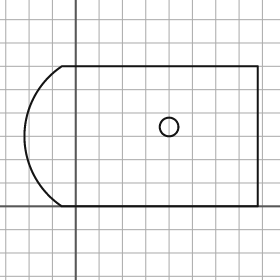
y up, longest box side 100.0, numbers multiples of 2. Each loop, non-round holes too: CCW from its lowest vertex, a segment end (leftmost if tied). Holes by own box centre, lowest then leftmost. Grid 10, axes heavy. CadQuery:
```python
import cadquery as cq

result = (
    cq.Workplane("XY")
    .moveTo(-6.0, 0.0)
    .lineTo(78.0, 0.0)
    .lineTo(78.0, 60.0)
    .lineTo(-6.0, 60.0)
    .threePointArc((-22.0, 30.0), (-6.0, 0.0))
    .close()
    .moveTo(40.0, 34.0)
    .circle(4.0)
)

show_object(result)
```